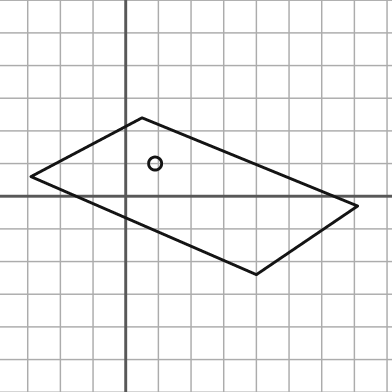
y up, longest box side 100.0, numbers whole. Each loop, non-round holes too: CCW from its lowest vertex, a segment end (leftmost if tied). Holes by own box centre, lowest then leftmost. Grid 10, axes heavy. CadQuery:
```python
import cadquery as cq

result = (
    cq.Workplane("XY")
    .moveTo(40.0, -24.0)
    .lineTo(71.0, -3.0)
    .lineTo(5.0, 24.0)
    .lineTo(-29.0, 6.0)
    .close()
    .moveTo(9.0, 10.0)
    .circle(2.0)
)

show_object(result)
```